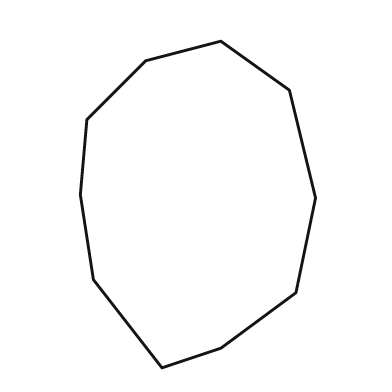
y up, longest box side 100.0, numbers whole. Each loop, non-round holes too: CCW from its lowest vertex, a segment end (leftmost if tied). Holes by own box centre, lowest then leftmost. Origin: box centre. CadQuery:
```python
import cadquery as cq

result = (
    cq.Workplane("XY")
    .moveTo(-11.0, -50.0)
    .lineTo(7.0, -44.0)
    .lineTo(30.0, -27.0)
    .lineTo(36.0, 2.0)
    .lineTo(28.0, 35.0)
    .lineTo(7.0, 50.0)
    .lineTo(-16.0, 44.0)
    .lineTo(-34.0, 26.0)
    .lineTo(-36.0, 3.0)
    .lineTo(-32.0, -23.0)
    .close()
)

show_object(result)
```